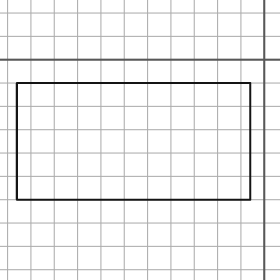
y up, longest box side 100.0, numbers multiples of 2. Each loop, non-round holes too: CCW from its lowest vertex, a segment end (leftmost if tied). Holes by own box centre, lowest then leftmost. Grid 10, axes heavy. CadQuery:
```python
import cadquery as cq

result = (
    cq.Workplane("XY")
    .moveTo(-106.0, -60.0)
    .lineTo(-6.0, -60.0)
    .lineTo(-6.0, -10.0)
    .lineTo(-106.0, -10.0)
    .close()
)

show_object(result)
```